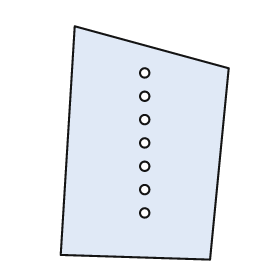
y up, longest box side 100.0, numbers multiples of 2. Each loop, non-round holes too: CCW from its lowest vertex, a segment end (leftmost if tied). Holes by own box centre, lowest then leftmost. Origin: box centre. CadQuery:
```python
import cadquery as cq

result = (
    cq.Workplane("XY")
    .moveTo(28.0, -50.0)
    .lineTo(36.0, 32.0)
    .lineTo(-30.0, 50.0)
    .lineTo(-36.0, -48.0)
    .close()
    .moveTo(0.0, -30.0)
    .circle(2.0)
    .moveTo(0.0, -20.0)
    .circle(2.0)
    .moveTo(0.0, -10.0)
    .circle(2.0)
    .moveTo(0.0, 0.0)
    .circle(2.0)
    .moveTo(0.0, 10.0)
    .circle(2.0)
    .moveTo(0.0, 20.0)
    .circle(2.0)
    .moveTo(0.0, 30.0)
    .circle(2.0)
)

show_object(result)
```